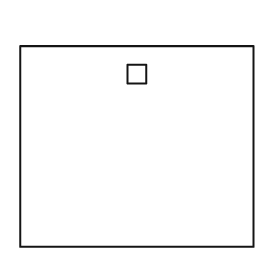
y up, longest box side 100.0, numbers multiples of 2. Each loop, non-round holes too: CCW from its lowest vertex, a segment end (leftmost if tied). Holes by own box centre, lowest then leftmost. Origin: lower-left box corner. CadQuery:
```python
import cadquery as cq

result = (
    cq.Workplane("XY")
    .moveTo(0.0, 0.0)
    .lineTo(100.0, 0.0)
    .lineTo(100.0, 86.0)
    .lineTo(0.0, 86.0)
    .close()
    .moveTo(46.0, 70.0)
    .lineTo(54.0, 70.0)
    .lineTo(54.0, 78.0)
    .lineTo(46.0, 78.0)
    .close()
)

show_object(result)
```